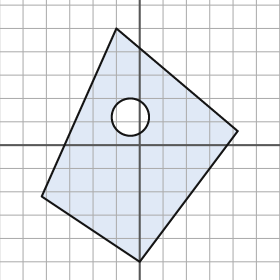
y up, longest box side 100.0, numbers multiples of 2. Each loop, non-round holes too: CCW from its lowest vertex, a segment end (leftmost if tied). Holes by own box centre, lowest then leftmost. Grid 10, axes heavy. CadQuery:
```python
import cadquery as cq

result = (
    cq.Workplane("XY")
    .moveTo(0.0, -50.0)
    .lineTo(42.0, 6.0)
    .lineTo(-10.0, 50.0)
    .lineTo(-42.0, -22.0)
    .close()
    .moveTo(-4.0, 12.0)
    .circle(8.0)
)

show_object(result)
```